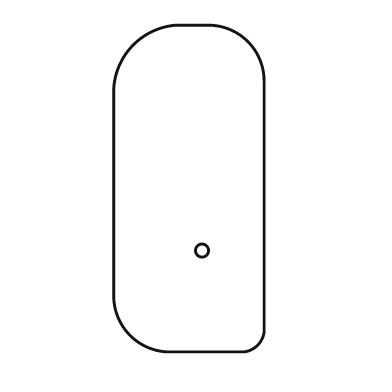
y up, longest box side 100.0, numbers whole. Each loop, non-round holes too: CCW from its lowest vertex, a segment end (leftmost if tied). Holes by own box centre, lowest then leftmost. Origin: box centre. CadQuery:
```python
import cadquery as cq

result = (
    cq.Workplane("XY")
    .moveTo(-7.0, -50.0)
    .lineTo(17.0, -50.0)
    .threePointArc((21.0, -48.0), (23.0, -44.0))
    .lineTo(23.0, 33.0)
    .threePointArc((18.0, 45.0), (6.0, 50.0))
    .lineTo(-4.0, 50.0)
    .threePointArc((-17.0, 44.0), (-23.0, 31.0))
    .lineTo(-23.0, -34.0)
    .threePointArc((-18.0, -45.0), (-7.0, -50.0))
    .close()
    .moveTo(4.0, -19.0)
    .circle(2.0)
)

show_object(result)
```